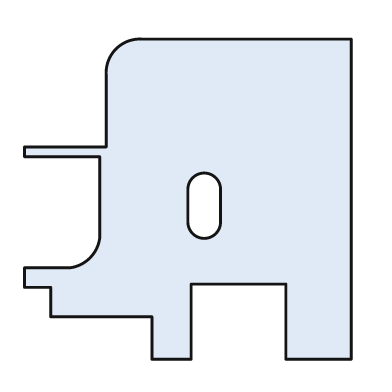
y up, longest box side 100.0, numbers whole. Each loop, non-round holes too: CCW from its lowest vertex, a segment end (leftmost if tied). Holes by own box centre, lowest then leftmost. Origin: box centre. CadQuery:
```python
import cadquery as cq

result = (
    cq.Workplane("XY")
    .moveTo(-11.0, -49.0)
    .lineTo(1.0, -49.0)
    .lineTo(1.0, -26.0)
    .lineTo(30.0, -26.0)
    .lineTo(30.0, -49.0)
    .lineTo(50.0, -49.0)
    .lineTo(50.0, 49.0)
    .lineTo(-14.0, 49.0)
    .threePointArc((-22.0, 46.0), (-25.0, 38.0))
    .lineTo(-25.0, 16.0)
    .lineTo(-50.0, 16.0)
    .lineTo(-50.0, 13.0)
    .lineTo(-27.0, 13.0)
    .lineTo(-27.0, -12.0)
    .threePointArc((-30.0, -18.0), (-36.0, -21.0))
    .lineTo(-50.0, -21.0)
    .lineTo(-50.0, -27.0)
    .lineTo(-42.0, -27.0)
    .lineTo(-42.0, -36.0)
    .lineTo(-11.0, -36.0)
    .close()
    .moveTo(0.0, -7.0)
    .threePointArc((5.0, -12.0), (10.0, -7.0))
    .lineTo(10.0, 3.0)
    .threePointArc((5.0, 8.0), (0.0, 3.0))
    .close()
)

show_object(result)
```